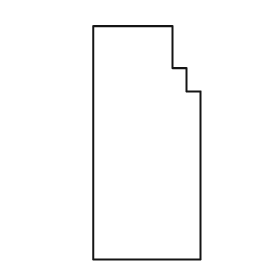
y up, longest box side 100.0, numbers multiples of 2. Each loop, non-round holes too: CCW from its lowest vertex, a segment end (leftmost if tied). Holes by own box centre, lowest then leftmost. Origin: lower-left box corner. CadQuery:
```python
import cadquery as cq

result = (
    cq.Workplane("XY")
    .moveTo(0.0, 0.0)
    .lineTo(46.0, 0.0)
    .lineTo(46.0, 72.0)
    .lineTo(40.0, 72.0)
    .lineTo(40.0, 82.0)
    .lineTo(34.0, 82.0)
    .lineTo(34.0, 100.0)
    .lineTo(0.0, 100.0)
    .close()
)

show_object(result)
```